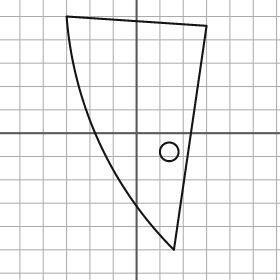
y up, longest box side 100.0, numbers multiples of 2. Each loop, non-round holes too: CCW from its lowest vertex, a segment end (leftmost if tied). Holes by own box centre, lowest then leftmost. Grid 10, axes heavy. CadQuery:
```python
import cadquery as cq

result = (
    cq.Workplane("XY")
    .moveTo(16.0, -50.0)
    .lineTo(30.0, 46.0)
    .lineTo(-30.0, 50.0)
    .threePointArc((-16.0, -4.0), (16.0, -50.0))
    .close()
    .moveTo(14.0, -8.0)
    .circle(4.0)
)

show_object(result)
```